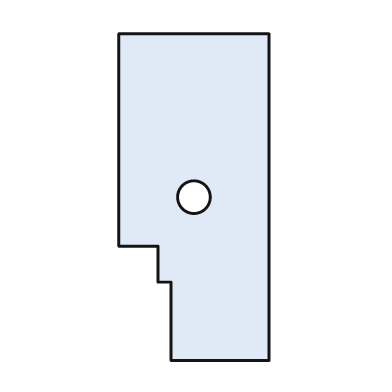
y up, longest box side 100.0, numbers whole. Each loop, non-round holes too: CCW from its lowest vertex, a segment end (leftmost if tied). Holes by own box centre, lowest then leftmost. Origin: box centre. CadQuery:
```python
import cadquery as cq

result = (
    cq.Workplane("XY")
    .moveTo(-7.0, -50.0)
    .lineTo(23.0, -50.0)
    .lineTo(23.0, 50.0)
    .lineTo(-23.0, 50.0)
    .lineTo(-23.0, -15.0)
    .lineTo(-11.0, -15.0)
    .lineTo(-11.0, -26.0)
    .lineTo(-7.0, -26.0)
    .close()
    .moveTo(0.0, 0.0)
    .circle(5.0)
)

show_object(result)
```